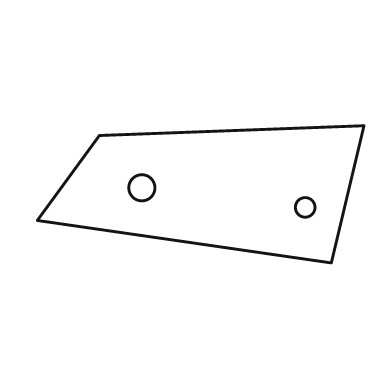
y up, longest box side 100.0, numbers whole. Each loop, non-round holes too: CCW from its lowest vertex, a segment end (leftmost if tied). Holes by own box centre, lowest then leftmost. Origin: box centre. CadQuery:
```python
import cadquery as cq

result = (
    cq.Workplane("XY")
    .moveTo(40.0, -21.0)
    .lineTo(50.0, 21.0)
    .lineTo(-31.0, 18.0)
    .lineTo(-50.0, -8.0)
    .close()
    .moveTo(32.0, -4.0)
    .circle(3.0)
    .moveTo(-18.0, 2.0)
    .circle(4.0)
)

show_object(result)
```